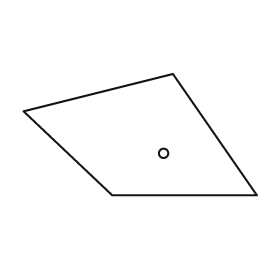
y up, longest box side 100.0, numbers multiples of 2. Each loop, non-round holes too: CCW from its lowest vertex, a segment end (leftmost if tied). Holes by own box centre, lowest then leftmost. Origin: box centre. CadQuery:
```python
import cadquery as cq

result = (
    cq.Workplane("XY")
    .moveTo(-12.0, -26.0)
    .lineTo(50.0, -26.0)
    .lineTo(14.0, 26.0)
    .lineTo(-50.0, 10.0)
    .close()
    .moveTo(10.0, -8.0)
    .circle(2.0)
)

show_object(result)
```